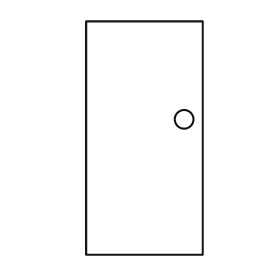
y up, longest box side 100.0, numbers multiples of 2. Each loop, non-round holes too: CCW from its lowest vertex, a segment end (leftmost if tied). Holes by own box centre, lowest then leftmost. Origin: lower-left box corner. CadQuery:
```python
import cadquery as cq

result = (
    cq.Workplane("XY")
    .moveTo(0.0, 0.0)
    .lineTo(50.0, 0.0)
    .lineTo(50.0, 100.0)
    .lineTo(0.0, 100.0)
    .close()
    .moveTo(42.0, 58.0)
    .circle(4.0)
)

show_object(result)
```